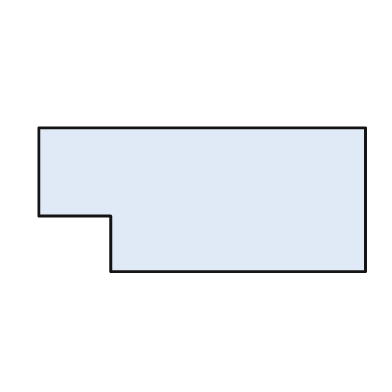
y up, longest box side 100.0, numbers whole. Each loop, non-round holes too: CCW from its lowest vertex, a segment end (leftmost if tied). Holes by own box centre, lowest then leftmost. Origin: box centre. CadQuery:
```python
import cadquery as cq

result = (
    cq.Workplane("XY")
    .moveTo(-28.0, -22.0)
    .lineTo(50.0, -22.0)
    .lineTo(50.0, 22.0)
    .lineTo(-50.0, 22.0)
    .lineTo(-50.0, -5.0)
    .lineTo(-28.0, -5.0)
    .close()
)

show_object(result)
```